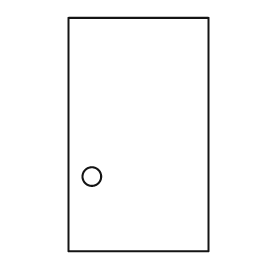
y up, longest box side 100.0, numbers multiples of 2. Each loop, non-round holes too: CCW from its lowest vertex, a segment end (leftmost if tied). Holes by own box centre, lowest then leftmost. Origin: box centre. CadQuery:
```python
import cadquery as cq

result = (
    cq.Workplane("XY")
    .moveTo(-30.0, -50.0)
    .lineTo(30.0, -50.0)
    .lineTo(30.0, 50.0)
    .lineTo(-30.0, 50.0)
    .close()
    .moveTo(-20.0, -18.0)
    .circle(4.0)
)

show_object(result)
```